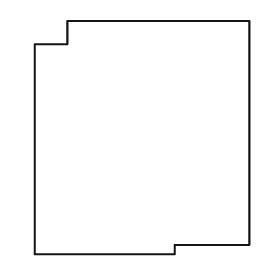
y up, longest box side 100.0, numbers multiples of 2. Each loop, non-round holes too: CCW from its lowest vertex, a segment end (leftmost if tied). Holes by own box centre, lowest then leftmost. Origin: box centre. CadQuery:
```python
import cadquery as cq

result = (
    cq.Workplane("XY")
    .moveTo(-46.0, -50.0)
    .lineTo(14.0, -50.0)
    .lineTo(14.0, -46.0)
    .lineTo(46.0, -46.0)
    .lineTo(46.0, 50.0)
    .lineTo(-32.0, 50.0)
    .lineTo(-32.0, 40.0)
    .lineTo(-46.0, 40.0)
    .close()
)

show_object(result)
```